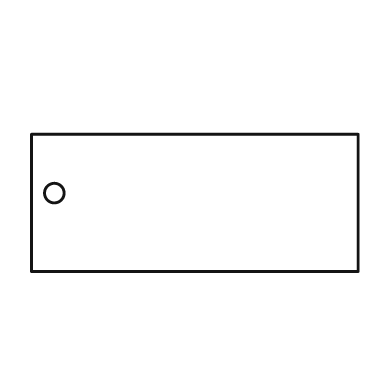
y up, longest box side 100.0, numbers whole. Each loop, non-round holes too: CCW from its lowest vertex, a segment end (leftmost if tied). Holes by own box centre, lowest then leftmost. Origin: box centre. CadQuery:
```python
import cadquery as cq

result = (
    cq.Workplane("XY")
    .moveTo(-50.0, -21.0)
    .lineTo(50.0, -21.0)
    .lineTo(50.0, 21.0)
    .lineTo(-50.0, 21.0)
    .close()
    .moveTo(-43.0, 3.0)
    .circle(3.0)
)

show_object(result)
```